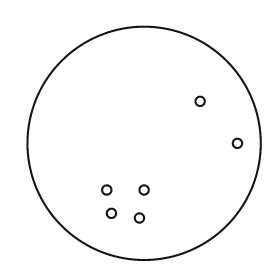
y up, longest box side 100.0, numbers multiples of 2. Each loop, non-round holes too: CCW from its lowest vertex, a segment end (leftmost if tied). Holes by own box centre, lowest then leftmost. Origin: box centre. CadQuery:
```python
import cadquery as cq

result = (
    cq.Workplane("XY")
    .moveTo(0.0, 0.0)
    .circle(50.0)
    .moveTo(-2.0, -32.0)
    .circle(2.0)
    .moveTo(-14.0, -30.0)
    .circle(2.0)
    .moveTo(-16.0, -20.0)
    .circle(2.0)
    .moveTo(0.0, -20.0)
    .circle(2.0)
    .moveTo(40.0, 0.0)
    .circle(2.0)
    .moveTo(24.0, 18.0)
    .circle(2.0)
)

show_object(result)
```